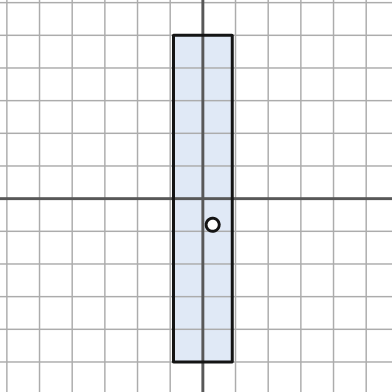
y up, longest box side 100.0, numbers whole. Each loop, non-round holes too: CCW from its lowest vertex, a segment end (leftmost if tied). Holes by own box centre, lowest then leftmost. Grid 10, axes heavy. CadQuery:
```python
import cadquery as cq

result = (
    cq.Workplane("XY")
    .moveTo(-9.0, -50.0)
    .lineTo(9.0, -50.0)
    .lineTo(9.0, 50.0)
    .lineTo(-9.0, 50.0)
    .close()
    .moveTo(3.0, -8.0)
    .circle(2.0)
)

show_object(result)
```